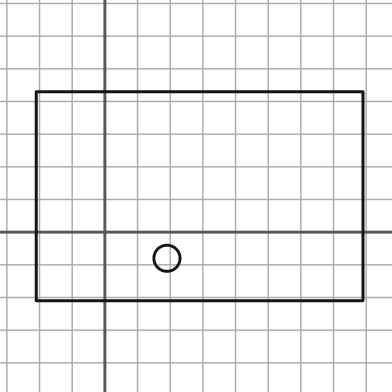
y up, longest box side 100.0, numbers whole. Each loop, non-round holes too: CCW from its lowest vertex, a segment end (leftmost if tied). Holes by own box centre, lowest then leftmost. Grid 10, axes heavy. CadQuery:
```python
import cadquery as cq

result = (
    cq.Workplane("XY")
    .moveTo(-21.0, -21.0)
    .lineTo(79.0, -21.0)
    .lineTo(79.0, 43.0)
    .lineTo(-21.0, 43.0)
    .close()
    .moveTo(19.0, -8.0)
    .circle(4.0)
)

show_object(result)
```